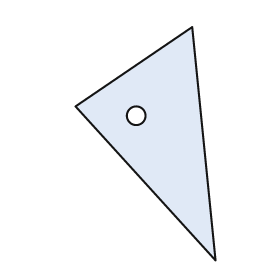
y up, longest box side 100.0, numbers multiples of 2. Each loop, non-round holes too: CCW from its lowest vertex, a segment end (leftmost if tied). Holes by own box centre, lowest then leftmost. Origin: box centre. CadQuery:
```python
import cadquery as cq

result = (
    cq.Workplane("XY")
    .moveTo(30.0, -50.0)
    .lineTo(20.0, 50.0)
    .lineTo(-30.0, 16.0)
    .close()
    .moveTo(-4.0, 12.0)
    .circle(4.0)
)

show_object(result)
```